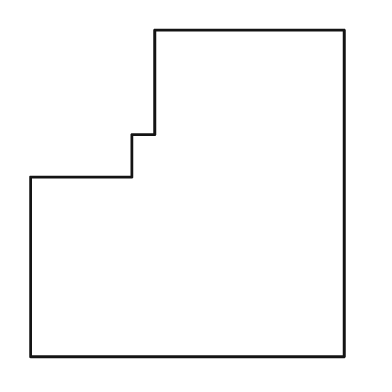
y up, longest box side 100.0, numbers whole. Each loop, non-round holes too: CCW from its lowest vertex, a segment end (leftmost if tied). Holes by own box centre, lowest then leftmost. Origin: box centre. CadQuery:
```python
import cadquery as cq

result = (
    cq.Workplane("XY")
    .moveTo(-48.0, -50.0)
    .lineTo(48.0, -50.0)
    .lineTo(48.0, 50.0)
    .lineTo(-10.0, 50.0)
    .lineTo(-10.0, 18.0)
    .lineTo(-17.0, 18.0)
    .lineTo(-17.0, 5.0)
    .lineTo(-48.0, 5.0)
    .close()
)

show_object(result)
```